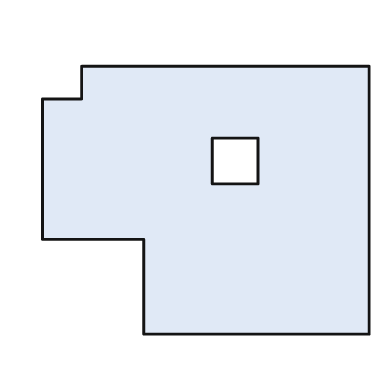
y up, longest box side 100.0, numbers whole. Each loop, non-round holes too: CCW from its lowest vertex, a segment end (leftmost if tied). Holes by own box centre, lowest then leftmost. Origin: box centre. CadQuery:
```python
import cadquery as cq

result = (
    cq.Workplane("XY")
    .moveTo(-19.0, -41.0)
    .lineTo(50.0, -41.0)
    .lineTo(50.0, 41.0)
    .lineTo(-38.0, 41.0)
    .lineTo(-38.0, 31.0)
    .lineTo(-50.0, 31.0)
    .lineTo(-50.0, -12.0)
    .lineTo(-19.0, -12.0)
    .close()
    .moveTo(2.0, 5.0)
    .lineTo(16.0, 5.0)
    .lineTo(16.0, 19.0)
    .lineTo(2.0, 19.0)
    .close()
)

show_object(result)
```